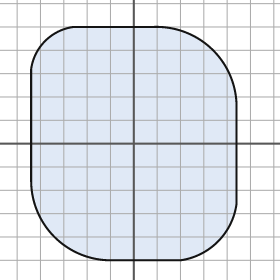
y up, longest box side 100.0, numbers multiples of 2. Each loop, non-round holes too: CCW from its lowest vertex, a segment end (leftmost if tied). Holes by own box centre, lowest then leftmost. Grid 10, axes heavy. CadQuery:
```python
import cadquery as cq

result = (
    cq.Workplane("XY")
    .moveTo(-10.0, -50.0)
    .lineTo(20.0, -50.0)
    .threePointArc((36.0, -42.0), (44.0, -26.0))
    .lineTo(44.0, 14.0)
    .threePointArc((34.0, 40.0), (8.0, 50.0))
    .lineTo(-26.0, 50.0)
    .threePointArc((-38.0, 44.0), (-44.0, 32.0))
    .lineTo(-44.0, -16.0)
    .threePointArc((-34.0, -40.0), (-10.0, -50.0))
    .close()
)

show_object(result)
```